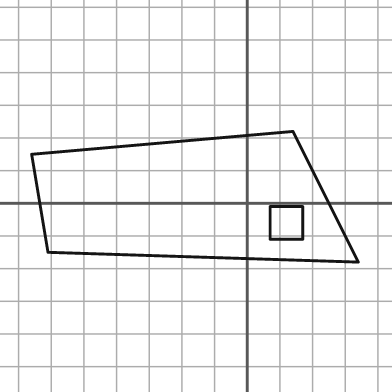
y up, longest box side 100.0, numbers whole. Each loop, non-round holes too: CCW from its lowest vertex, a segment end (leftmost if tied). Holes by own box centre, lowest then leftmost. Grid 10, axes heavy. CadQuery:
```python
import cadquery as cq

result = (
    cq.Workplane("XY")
    .moveTo(34.0, -18.0)
    .lineTo(14.0, 22.0)
    .lineTo(-66.0, 15.0)
    .lineTo(-61.0, -15.0)
    .close()
    .moveTo(7.0, -11.0)
    .lineTo(17.0, -11.0)
    .lineTo(17.0, -1.0)
    .lineTo(7.0, -1.0)
    .close()
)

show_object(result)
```